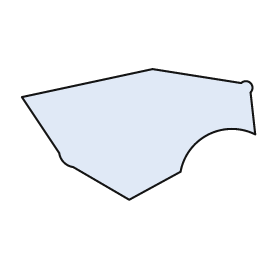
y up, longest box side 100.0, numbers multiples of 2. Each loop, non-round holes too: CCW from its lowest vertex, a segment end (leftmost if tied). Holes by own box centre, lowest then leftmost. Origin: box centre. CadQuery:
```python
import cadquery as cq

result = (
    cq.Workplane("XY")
    .moveTo(-4.0, -28.0)
    .lineTo(18.0, -16.0)
    .threePointArc((30.0, 0.0), (50.0, 0.0))
    .lineTo(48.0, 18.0)
    .threePointArc((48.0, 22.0), (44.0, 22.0))
    .lineTo(6.0, 28.0)
    .lineTo(-50.0, 16.0)
    .lineTo(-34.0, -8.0)
    .threePointArc((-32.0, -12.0), (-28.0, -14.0))
    .close()
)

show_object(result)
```